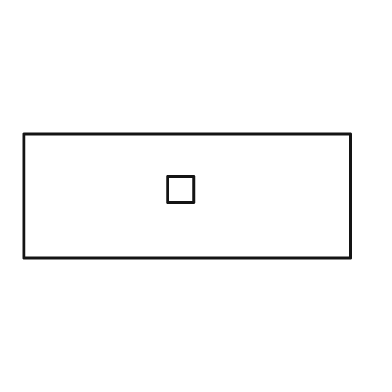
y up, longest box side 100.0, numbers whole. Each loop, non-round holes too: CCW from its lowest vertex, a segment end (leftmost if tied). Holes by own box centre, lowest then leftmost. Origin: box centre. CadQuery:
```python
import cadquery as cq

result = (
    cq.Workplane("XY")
    .moveTo(-50.0, -19.0)
    .lineTo(50.0, -19.0)
    .lineTo(50.0, 19.0)
    .lineTo(-50.0, 19.0)
    .close()
    .moveTo(-6.0, -2.0)
    .lineTo(2.0, -2.0)
    .lineTo(2.0, 6.0)
    .lineTo(-6.0, 6.0)
    .close()
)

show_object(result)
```